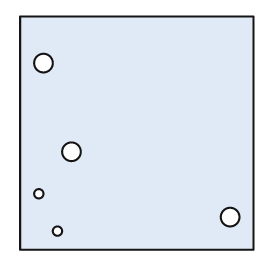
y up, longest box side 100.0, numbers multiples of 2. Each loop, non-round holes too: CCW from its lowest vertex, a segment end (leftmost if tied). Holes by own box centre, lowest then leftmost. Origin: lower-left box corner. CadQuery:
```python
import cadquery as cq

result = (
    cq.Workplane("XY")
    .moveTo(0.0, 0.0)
    .lineTo(100.0, 0.0)
    .lineTo(100.0, 100.0)
    .lineTo(0.0, 100.0)
    .close()
    .moveTo(16.0, 8.0)
    .circle(2.0)
    .moveTo(90.0, 14.0)
    .circle(4.0)
    .moveTo(8.0, 24.0)
    .circle(2.0)
    .moveTo(22.0, 42.0)
    .circle(4.0)
    .moveTo(10.0, 80.0)
    .circle(4.0)
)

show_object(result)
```